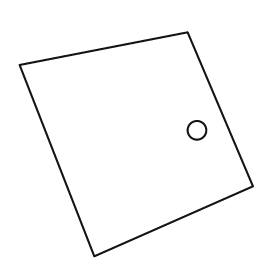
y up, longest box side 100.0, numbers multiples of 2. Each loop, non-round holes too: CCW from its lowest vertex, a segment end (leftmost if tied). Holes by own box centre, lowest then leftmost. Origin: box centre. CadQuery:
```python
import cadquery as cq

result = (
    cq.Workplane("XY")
    .moveTo(-18.0, -48.0)
    .lineTo(50.0, -18.0)
    .lineTo(22.0, 48.0)
    .lineTo(-50.0, 34.0)
    .close()
    .moveTo(26.0, 6.0)
    .circle(4.0)
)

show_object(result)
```